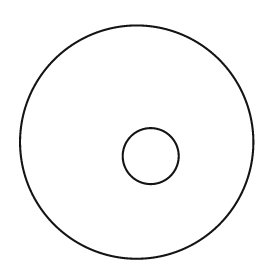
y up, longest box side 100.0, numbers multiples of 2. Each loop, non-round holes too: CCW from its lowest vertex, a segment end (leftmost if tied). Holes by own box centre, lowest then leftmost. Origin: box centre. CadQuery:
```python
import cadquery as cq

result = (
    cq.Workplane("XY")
    .moveTo(0.0, 0.0)
    .circle(50.0)
    .moveTo(6.0, -6.0)
    .circle(12.0)
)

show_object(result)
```